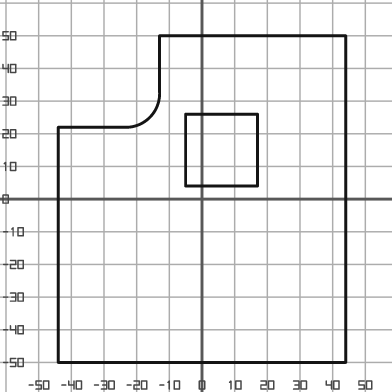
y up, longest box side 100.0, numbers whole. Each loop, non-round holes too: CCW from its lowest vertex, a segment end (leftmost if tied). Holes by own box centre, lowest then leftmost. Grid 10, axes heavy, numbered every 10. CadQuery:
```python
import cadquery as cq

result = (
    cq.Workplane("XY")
    .moveTo(-44.0, -50.0)
    .lineTo(44.0, -50.0)
    .lineTo(44.0, 50.0)
    .lineTo(-13.0, 50.0)
    .lineTo(-13.0, 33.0)
    .threePointArc((-16.0, 25.0), (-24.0, 22.0))
    .lineTo(-44.0, 22.0)
    .close()
    .moveTo(-5.0, 4.0)
    .lineTo(17.0, 4.0)
    .lineTo(17.0, 26.0)
    .lineTo(-5.0, 26.0)
    .close()
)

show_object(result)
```